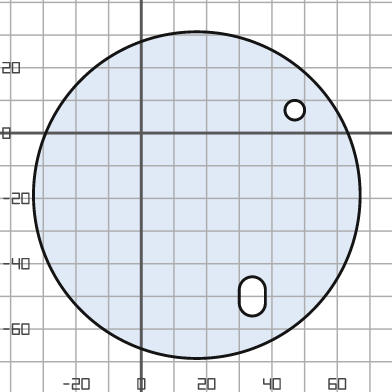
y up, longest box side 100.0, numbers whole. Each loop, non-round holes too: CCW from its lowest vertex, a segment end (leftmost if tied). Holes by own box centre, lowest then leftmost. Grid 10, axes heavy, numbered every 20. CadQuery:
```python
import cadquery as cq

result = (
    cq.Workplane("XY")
    .moveTo(17.0, -19.0)
    .circle(50.0)
    .moveTo(30.0, -52.0)
    .threePointArc((34.0, -56.0), (38.0, -52.0))
    .lineTo(38.0, -48.0)
    .threePointArc((34.0, -44.0), (30.0, -48.0))
    .close()
    .moveTo(47.0, 7.0)
    .circle(3.0)
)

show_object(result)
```